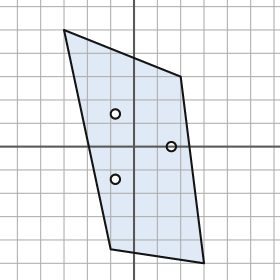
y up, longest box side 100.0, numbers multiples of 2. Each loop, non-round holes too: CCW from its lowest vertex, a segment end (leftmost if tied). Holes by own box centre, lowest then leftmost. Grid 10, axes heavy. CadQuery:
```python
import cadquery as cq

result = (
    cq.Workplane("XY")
    .moveTo(30.0, -50.0)
    .lineTo(20.0, 30.0)
    .lineTo(-30.0, 50.0)
    .lineTo(-10.0, -44.0)
    .close()
    .moveTo(-8.0, -14.0)
    .circle(2.0)
    .moveTo(16.0, 0.0)
    .circle(2.0)
    .moveTo(-8.0, 14.0)
    .circle(2.0)
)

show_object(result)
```